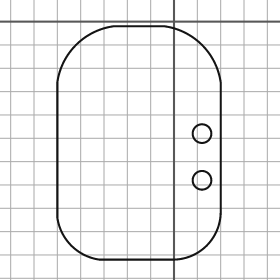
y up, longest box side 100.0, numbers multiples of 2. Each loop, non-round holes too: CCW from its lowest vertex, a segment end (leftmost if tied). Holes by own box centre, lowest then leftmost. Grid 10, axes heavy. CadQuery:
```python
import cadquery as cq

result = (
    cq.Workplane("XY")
    .moveTo(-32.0, -102.0)
    .lineTo(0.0, -102.0)
    .threePointArc((14.0, -96.0), (20.0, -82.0))
    .lineTo(20.0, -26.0)
    .threePointArc((12.0, -10.0), (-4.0, -2.0))
    .lineTo(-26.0, -2.0)
    .threePointArc((-42.0, -10.0), (-50.0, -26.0))
    .lineTo(-50.0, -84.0)
    .threePointArc((-44.0, -96.0), (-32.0, -102.0))
    .close()
    .moveTo(12.0, -68.0)
    .circle(4.0)
    .moveTo(12.0, -48.0)
    .circle(4.0)
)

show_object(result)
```